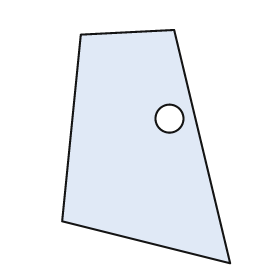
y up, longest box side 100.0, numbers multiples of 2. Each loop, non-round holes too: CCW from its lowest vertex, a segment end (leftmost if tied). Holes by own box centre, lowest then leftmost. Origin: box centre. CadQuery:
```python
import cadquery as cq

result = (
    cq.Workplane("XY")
    .moveTo(36.0, -50.0)
    .lineTo(12.0, 50.0)
    .lineTo(-28.0, 48.0)
    .lineTo(-36.0, -32.0)
    .close()
    .moveTo(10.0, 12.0)
    .circle(6.0)
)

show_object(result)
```